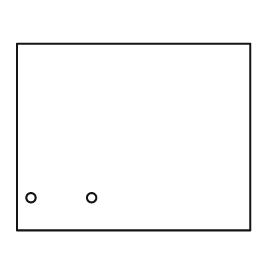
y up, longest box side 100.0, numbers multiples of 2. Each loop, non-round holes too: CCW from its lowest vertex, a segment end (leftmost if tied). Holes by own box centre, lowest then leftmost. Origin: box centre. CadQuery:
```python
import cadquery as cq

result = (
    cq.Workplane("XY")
    .moveTo(-50.0, -40.0)
    .lineTo(50.0, -40.0)
    .lineTo(50.0, 40.0)
    .lineTo(-50.0, 40.0)
    .close()
    .moveTo(-44.0, -26.0)
    .circle(2.0)
    .moveTo(-18.0, -26.0)
    .circle(2.0)
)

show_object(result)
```